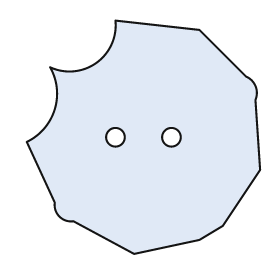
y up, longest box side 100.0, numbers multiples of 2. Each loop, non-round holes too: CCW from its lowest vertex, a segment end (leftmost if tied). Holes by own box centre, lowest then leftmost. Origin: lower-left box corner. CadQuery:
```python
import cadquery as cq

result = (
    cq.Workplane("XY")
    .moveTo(46.0, 0.0)
    .lineTo(74.0, 6.0)
    .lineTo(84.0, 12.0)
    .lineTo(100.0, 36.0)
    .lineTo(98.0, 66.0)
    .threePointArc((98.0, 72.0), (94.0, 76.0))
    .lineTo(74.0, 96.0)
    .lineTo(38.0, 100.0)
    .threePointArc((30.0, 82.0), (10.0, 80.0))
    .threePointArc((12.0, 62.0), (0.0, 48.0))
    .lineTo(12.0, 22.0)
    .threePointArc((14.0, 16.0), (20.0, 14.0))
    .close()
    .moveTo(38.0, 50.0)
    .circle(4.0)
    .moveTo(62.0, 50.0)
    .circle(4.0)
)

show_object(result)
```